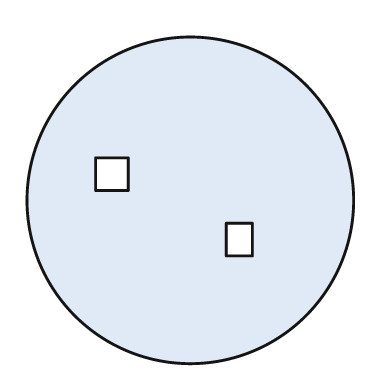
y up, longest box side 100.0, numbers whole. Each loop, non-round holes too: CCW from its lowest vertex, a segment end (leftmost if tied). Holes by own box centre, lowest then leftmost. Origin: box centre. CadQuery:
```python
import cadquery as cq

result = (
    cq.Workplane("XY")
    .moveTo(0.0, 0.0)
    .circle(50.0)
    .moveTo(11.0, -17.0)
    .lineTo(19.0, -17.0)
    .lineTo(19.0, -7.0)
    .lineTo(11.0, -7.0)
    .close()
    .moveTo(-29.0, 3.0)
    .lineTo(-19.0, 3.0)
    .lineTo(-19.0, 13.0)
    .lineTo(-29.0, 13.0)
    .close()
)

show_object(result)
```